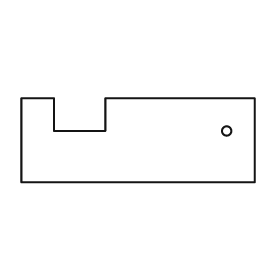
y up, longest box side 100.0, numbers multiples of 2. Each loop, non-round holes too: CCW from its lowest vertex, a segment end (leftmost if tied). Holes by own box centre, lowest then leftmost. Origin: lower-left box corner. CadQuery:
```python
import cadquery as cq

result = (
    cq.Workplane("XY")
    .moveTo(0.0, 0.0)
    .lineTo(100.0, 0.0)
    .lineTo(100.0, 36.0)
    .lineTo(36.0, 36.0)
    .lineTo(36.0, 22.0)
    .lineTo(14.0, 22.0)
    .lineTo(14.0, 36.0)
    .lineTo(0.0, 36.0)
    .close()
    .moveTo(88.0, 22.0)
    .circle(2.0)
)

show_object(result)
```